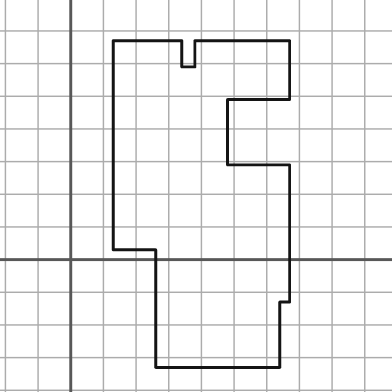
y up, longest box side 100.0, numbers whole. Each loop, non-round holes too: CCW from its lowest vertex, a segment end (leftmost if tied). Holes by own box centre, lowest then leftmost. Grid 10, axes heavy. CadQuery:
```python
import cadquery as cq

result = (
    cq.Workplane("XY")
    .moveTo(26.0, -33.0)
    .lineTo(64.0, -33.0)
    .lineTo(64.0, -13.0)
    .lineTo(67.0, -13.0)
    .lineTo(67.0, 29.0)
    .lineTo(48.0, 29.0)
    .lineTo(48.0, 49.0)
    .lineTo(67.0, 49.0)
    .lineTo(67.0, 67.0)
    .lineTo(38.0, 67.0)
    .lineTo(38.0, 59.0)
    .lineTo(34.0, 59.0)
    .lineTo(34.0, 67.0)
    .lineTo(13.0, 67.0)
    .lineTo(13.0, 3.0)
    .lineTo(26.0, 3.0)
    .close()
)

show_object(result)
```